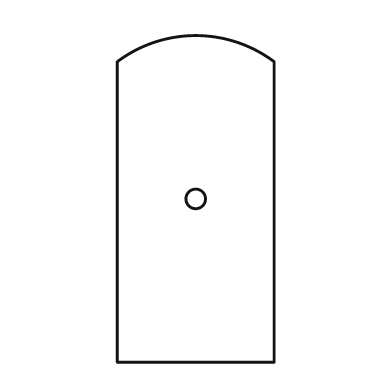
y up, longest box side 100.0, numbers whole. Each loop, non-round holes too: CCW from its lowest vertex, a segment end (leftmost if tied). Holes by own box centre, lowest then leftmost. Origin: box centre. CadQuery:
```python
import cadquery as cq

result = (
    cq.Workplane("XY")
    .moveTo(-24.0, -50.0)
    .lineTo(24.0, -50.0)
    .lineTo(24.0, 42.0)
    .threePointArc((0.0, 50.0), (-24.0, 42.0))
    .close()
    .moveTo(0.0, 0.0)
    .circle(3.0)
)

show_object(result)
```